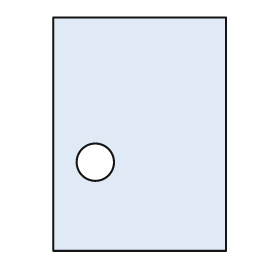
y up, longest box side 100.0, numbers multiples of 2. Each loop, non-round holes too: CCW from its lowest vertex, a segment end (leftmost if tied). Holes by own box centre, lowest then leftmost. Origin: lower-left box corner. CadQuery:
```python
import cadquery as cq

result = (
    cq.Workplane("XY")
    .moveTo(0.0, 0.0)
    .lineTo(74.0, 0.0)
    .lineTo(74.0, 100.0)
    .lineTo(0.0, 100.0)
    .close()
    .moveTo(18.0, 38.0)
    .circle(8.0)
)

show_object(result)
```